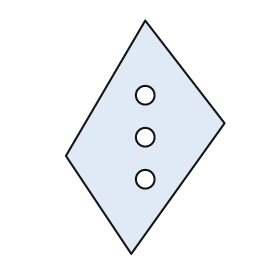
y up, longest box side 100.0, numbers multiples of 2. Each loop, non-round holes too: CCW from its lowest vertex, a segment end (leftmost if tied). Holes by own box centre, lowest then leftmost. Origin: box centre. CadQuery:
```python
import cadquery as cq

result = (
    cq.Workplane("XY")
    .moveTo(-6.0, -50.0)
    .lineTo(34.0, 6.0)
    .lineTo(0.0, 50.0)
    .lineTo(-34.0, -8.0)
    .close()
    .moveTo(0.0, -18.0)
    .circle(4.0)
    .moveTo(0.0, 0.0)
    .circle(4.0)
    .moveTo(0.0, 18.0)
    .circle(4.0)
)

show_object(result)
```